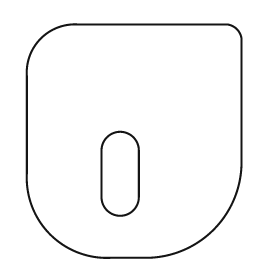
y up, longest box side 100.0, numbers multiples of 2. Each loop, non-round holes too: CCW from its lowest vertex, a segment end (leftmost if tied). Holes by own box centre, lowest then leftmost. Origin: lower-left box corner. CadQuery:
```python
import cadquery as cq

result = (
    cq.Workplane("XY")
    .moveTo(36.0, 0.0)
    .lineTo(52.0, 0.0)
    .threePointArc((80.0, 12.0), (92.0, 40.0))
    .lineTo(92.0, 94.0)
    .threePointArc((90.0, 98.0), (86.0, 100.0))
    .lineTo(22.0, 100.0)
    .threePointArc((6.0, 94.0), (0.0, 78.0))
    .lineTo(0.0, 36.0)
    .threePointArc((10.0, 10.0), (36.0, 0.0))
    .close()
    .moveTo(32.0, 26.0)
    .threePointArc((40.0, 18.0), (48.0, 26.0))
    .lineTo(48.0, 46.0)
    .threePointArc((40.0, 54.0), (32.0, 46.0))
    .close()
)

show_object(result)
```